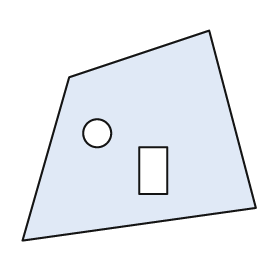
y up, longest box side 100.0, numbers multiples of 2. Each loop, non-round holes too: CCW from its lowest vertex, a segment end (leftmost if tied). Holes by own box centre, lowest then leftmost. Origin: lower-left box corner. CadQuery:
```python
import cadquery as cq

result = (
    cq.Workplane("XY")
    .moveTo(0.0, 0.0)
    .lineTo(100.0, 14.0)
    .lineTo(80.0, 90.0)
    .lineTo(20.0, 70.0)
    .close()
    .moveTo(50.0, 20.0)
    .lineTo(62.0, 20.0)
    .lineTo(62.0, 40.0)
    .lineTo(50.0, 40.0)
    .close()
    .moveTo(32.0, 46.0)
    .circle(6.0)
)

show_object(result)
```